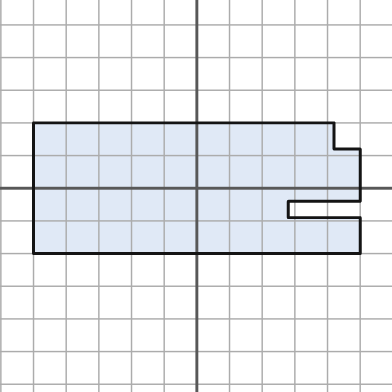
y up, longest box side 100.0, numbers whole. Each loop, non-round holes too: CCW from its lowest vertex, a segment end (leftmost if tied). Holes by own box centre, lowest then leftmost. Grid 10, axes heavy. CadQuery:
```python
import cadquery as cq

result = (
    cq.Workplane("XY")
    .moveTo(-50.0, -20.0)
    .lineTo(50.0, -20.0)
    .lineTo(50.0, -9.0)
    .lineTo(28.0, -9.0)
    .lineTo(28.0, -4.0)
    .lineTo(50.0, -4.0)
    .lineTo(50.0, 12.0)
    .lineTo(42.0, 12.0)
    .lineTo(42.0, 20.0)
    .lineTo(-50.0, 20.0)
    .close()
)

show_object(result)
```